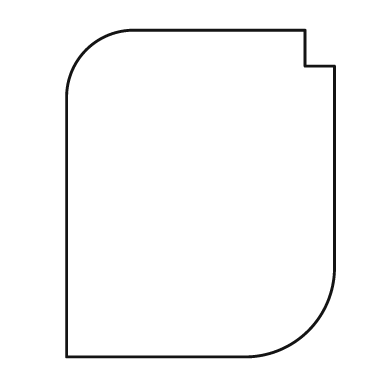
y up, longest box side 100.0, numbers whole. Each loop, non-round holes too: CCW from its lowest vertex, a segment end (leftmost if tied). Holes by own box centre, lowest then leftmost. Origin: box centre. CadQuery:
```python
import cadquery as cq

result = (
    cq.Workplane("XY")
    .moveTo(-41.0, -50.0)
    .lineTo(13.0, -50.0)
    .threePointArc((33.0, -42.0), (41.0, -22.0))
    .lineTo(41.0, 39.0)
    .lineTo(32.0, 39.0)
    .lineTo(32.0, 50.0)
    .lineTo(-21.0, 50.0)
    .threePointArc((-35.0, 44.0), (-41.0, 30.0))
    .close()
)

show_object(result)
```